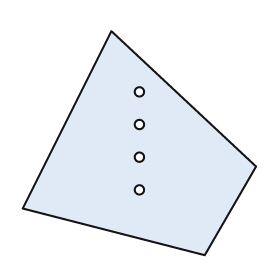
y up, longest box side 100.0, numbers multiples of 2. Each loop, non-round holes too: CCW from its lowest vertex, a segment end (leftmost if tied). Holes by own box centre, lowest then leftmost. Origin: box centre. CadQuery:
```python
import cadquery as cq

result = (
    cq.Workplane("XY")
    .moveTo(28.0, -48.0)
    .lineTo(50.0, -10.0)
    .lineTo(-12.0, 48.0)
    .lineTo(-50.0, -28.0)
    .close()
    .moveTo(0.0, -20.0)
    .circle(2.0)
    .moveTo(0.0, -6.0)
    .circle(2.0)
    .moveTo(0.0, 8.0)
    .circle(2.0)
    .moveTo(0.0, 22.0)
    .circle(2.0)
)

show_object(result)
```